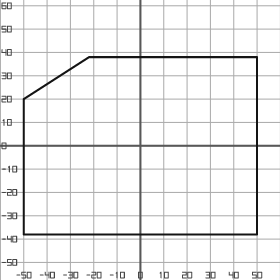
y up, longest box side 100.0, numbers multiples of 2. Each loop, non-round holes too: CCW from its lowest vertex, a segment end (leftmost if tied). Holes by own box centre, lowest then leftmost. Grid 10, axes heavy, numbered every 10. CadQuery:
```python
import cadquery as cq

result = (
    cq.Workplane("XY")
    .moveTo(-50.0, -38.0)
    .lineTo(50.0, -38.0)
    .lineTo(50.0, 38.0)
    .lineTo(-22.0, 38.0)
    .lineTo(-50.0, 20.0)
    .close()
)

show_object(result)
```